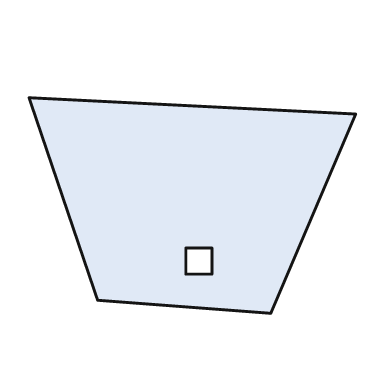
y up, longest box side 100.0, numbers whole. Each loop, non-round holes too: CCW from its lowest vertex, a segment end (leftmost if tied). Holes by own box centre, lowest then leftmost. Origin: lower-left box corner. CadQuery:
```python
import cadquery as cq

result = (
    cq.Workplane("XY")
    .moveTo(74.0, 0.0)
    .lineTo(100.0, 61.0)
    .lineTo(0.0, 66.0)
    .lineTo(21.0, 4.0)
    .close()
    .moveTo(48.0, 12.0)
    .lineTo(56.0, 12.0)
    .lineTo(56.0, 20.0)
    .lineTo(48.0, 20.0)
    .close()
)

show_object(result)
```